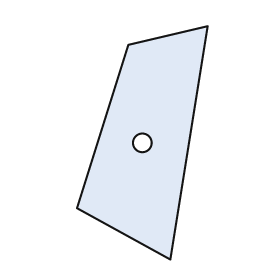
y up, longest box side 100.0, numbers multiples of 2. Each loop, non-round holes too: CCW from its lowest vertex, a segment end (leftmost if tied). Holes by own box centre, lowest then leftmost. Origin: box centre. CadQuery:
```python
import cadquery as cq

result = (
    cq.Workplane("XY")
    .moveTo(12.0, -50.0)
    .lineTo(28.0, 50.0)
    .lineTo(-6.0, 42.0)
    .lineTo(-28.0, -28.0)
    .close()
    .moveTo(0.0, 0.0)
    .circle(4.0)
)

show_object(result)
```